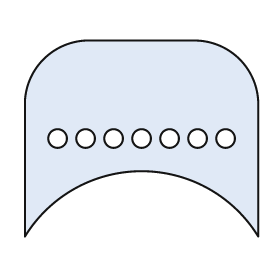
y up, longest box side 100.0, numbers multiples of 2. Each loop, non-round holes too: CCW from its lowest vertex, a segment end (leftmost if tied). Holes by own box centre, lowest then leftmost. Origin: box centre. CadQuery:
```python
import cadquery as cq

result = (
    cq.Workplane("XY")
    .moveTo(-50.0, -42.0)
    .threePointArc((0.0, -14.0), (50.0, -42.0))
    .lineTo(50.0, 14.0)
    .threePointArc((42.0, 34.0), (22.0, 42.0))
    .lineTo(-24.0, 42.0)
    .threePointArc((-42.0, 34.0), (-50.0, 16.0))
    .close()
    .moveTo(-36.0, 0.0)
    .circle(4.0)
    .moveTo(-24.0, 0.0)
    .circle(4.0)
    .moveTo(-12.0, 0.0)
    .circle(4.0)
    .moveTo(0.0, 0.0)
    .circle(4.0)
    .moveTo(12.0, 0.0)
    .circle(4.0)
    .moveTo(24.0, 0.0)
    .circle(4.0)
    .moveTo(36.0, 0.0)
    .circle(4.0)
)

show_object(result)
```